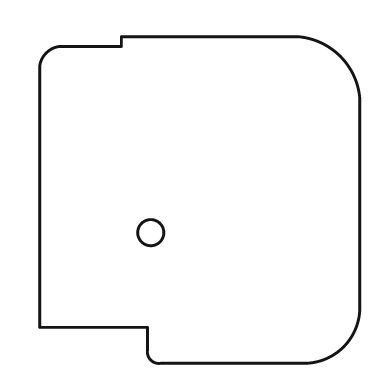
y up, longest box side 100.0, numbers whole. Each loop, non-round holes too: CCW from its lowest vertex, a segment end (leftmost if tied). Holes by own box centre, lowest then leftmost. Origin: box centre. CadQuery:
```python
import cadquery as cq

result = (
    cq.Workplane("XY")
    .moveTo(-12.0, -50.0)
    .lineTo(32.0, -50.0)
    .threePointArc((44.0, -45.0), (49.0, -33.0))
    .lineTo(49.0, 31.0)
    .threePointArc((43.0, 44.0), (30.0, 50.0))
    .lineTo(-24.0, 50.0)
    .lineTo(-24.0, 47.0)
    .lineTo(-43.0, 47.0)
    .threePointArc((-47.0, 45.0), (-49.0, 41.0))
    .lineTo(-49.0, -39.0)
    .lineTo(-16.0, -39.0)
    .lineTo(-16.0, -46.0)
    .threePointArc((-15.0, -49.0), (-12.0, -50.0))
    .close()
    .moveTo(-15.0, -10.0)
    .circle(4.0)
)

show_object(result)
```